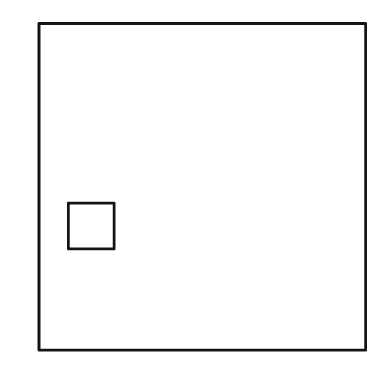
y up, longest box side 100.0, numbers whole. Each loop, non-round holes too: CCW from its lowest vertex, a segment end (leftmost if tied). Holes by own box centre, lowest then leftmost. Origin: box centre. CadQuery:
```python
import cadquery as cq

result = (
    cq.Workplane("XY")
    .moveTo(-50.0, -50.0)
    .lineTo(50.0, -50.0)
    .lineTo(50.0, 50.0)
    .lineTo(-50.0, 50.0)
    .close()
    .moveTo(-41.0, -19.0)
    .lineTo(-27.0, -19.0)
    .lineTo(-27.0, -5.0)
    .lineTo(-41.0, -5.0)
    .close()
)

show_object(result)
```